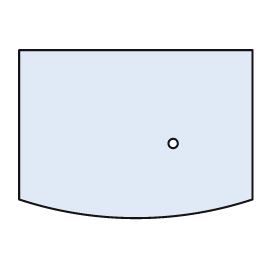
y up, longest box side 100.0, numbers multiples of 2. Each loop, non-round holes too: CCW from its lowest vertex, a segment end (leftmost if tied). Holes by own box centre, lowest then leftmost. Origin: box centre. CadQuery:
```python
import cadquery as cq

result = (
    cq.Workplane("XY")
    .moveTo(-50.0, -28.0)
    .threePointArc((0.0, -36.0), (50.0, -28.0))
    .lineTo(50.0, 36.0)
    .lineTo(-50.0, 36.0)
    .close()
    .moveTo(16.0, -4.0)
    .circle(2.0)
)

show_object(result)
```